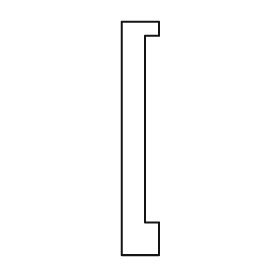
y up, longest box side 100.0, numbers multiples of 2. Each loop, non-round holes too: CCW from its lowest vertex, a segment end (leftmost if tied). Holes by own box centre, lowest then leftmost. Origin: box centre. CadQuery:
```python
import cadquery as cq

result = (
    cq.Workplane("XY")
    .moveTo(-8.0, -50.0)
    .lineTo(8.0, -50.0)
    .lineTo(8.0, -36.0)
    .lineTo(2.0, -36.0)
    .lineTo(2.0, 44.0)
    .lineTo(8.0, 44.0)
    .lineTo(8.0, 50.0)
    .lineTo(-8.0, 50.0)
    .close()
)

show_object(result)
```